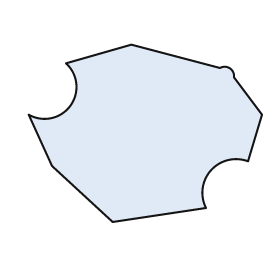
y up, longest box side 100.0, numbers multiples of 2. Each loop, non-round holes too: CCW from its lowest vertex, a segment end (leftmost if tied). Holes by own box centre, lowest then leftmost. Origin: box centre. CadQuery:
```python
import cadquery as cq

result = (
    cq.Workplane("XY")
    .moveTo(-14.0, -38.0)
    .lineTo(26.0, -32.0)
    .threePointArc((28.0, -16.0), (44.0, -12.0))
    .lineTo(50.0, 8.0)
    .lineTo(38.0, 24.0)
    .threePointArc((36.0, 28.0), (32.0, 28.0))
    .lineTo(-6.0, 38.0)
    .lineTo(-34.0, 30.0)
    .threePointArc((-32.0, 12.0), (-50.0, 8.0))
    .lineTo(-40.0, -14.0)
    .close()
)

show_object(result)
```